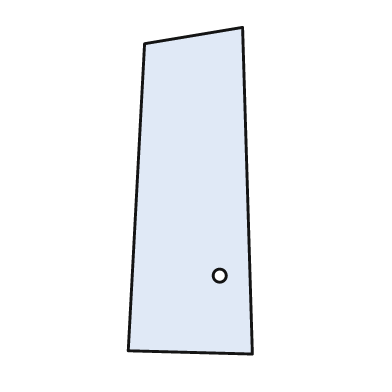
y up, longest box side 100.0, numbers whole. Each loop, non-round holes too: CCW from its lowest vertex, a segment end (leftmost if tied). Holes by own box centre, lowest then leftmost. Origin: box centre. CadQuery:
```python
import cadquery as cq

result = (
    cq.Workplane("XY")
    .moveTo(19.0, -50.0)
    .lineTo(16.0, 50.0)
    .lineTo(-14.0, 45.0)
    .lineTo(-19.0, -49.0)
    .close()
    .moveTo(9.0, -26.0)
    .circle(2.0)
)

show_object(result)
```